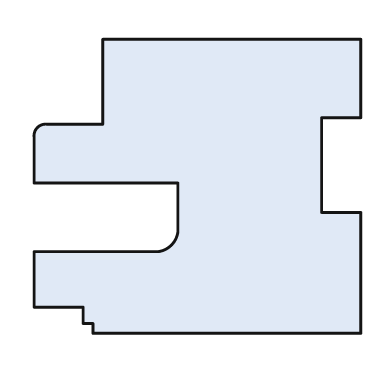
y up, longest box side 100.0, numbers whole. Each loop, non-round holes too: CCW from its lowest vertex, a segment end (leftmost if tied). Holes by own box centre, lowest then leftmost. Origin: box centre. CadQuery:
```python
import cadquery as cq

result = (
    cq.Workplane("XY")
    .moveTo(-32.0, -45.0)
    .lineTo(50.0, -45.0)
    .lineTo(50.0, -8.0)
    .lineTo(38.0, -8.0)
    .lineTo(38.0, 21.0)
    .lineTo(50.0, 21.0)
    .lineTo(50.0, 45.0)
    .lineTo(-29.0, 45.0)
    .lineTo(-29.0, 19.0)
    .lineTo(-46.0, 19.0)
    .threePointArc((-49.0, 18.0), (-50.0, 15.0))
    .lineTo(-50.0, 1.0)
    .lineTo(-6.0, 1.0)
    .lineTo(-6.0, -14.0)
    .threePointArc((-8.0, -18.0), (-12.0, -20.0))
    .lineTo(-50.0, -20.0)
    .lineTo(-50.0, -37.0)
    .lineTo(-35.0, -37.0)
    .lineTo(-35.0, -42.0)
    .lineTo(-32.0, -42.0)
    .close()
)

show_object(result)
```